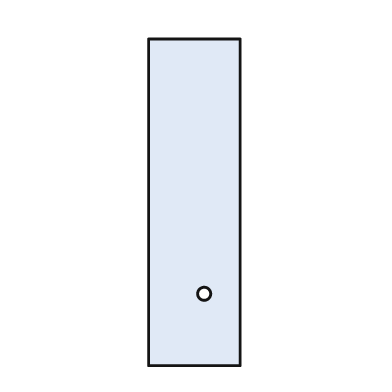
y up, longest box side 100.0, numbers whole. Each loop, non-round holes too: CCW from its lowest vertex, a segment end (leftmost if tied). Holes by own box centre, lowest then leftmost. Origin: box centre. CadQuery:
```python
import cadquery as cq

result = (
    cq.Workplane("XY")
    .moveTo(-14.0, -50.0)
    .lineTo(14.0, -50.0)
    .lineTo(14.0, 50.0)
    .lineTo(-14.0, 50.0)
    .close()
    .moveTo(3.0, -28.0)
    .circle(2.0)
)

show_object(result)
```